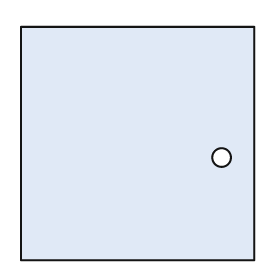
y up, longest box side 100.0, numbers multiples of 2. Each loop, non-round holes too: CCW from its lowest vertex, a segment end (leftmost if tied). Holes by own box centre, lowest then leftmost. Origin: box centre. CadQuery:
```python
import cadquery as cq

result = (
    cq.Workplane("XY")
    .moveTo(-50.0, -50.0)
    .lineTo(50.0, -50.0)
    .lineTo(50.0, 50.0)
    .lineTo(-50.0, 50.0)
    .close()
    .moveTo(36.0, -6.0)
    .circle(4.0)
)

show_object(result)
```